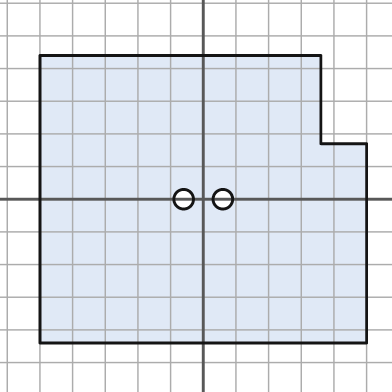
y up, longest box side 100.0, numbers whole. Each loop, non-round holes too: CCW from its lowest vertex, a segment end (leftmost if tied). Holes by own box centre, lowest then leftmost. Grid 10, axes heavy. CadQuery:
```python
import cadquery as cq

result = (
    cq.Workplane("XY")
    .moveTo(-50.0, -44.0)
    .lineTo(50.0, -44.0)
    .lineTo(50.0, 17.0)
    .lineTo(36.0, 17.0)
    .lineTo(36.0, 44.0)
    .lineTo(-50.0, 44.0)
    .close()
    .moveTo(-6.0, 0.0)
    .circle(3.0)
    .moveTo(6.0, 0.0)
    .circle(3.0)
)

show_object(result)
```